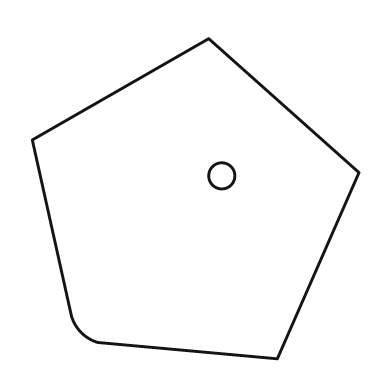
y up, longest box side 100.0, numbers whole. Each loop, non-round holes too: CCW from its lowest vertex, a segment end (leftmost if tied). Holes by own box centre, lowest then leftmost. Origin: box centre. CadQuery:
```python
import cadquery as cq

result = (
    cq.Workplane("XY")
    .moveTo(25.0, -49.0)
    .lineTo(50.0, 8.0)
    .lineTo(4.0, 49.0)
    .lineTo(-50.0, 18.0)
    .lineTo(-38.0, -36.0)
    .threePointArc((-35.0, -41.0), (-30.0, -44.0))
    .close()
    .moveTo(8.0, 7.0)
    .circle(4.0)
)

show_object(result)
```